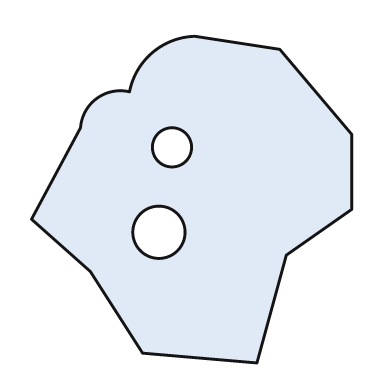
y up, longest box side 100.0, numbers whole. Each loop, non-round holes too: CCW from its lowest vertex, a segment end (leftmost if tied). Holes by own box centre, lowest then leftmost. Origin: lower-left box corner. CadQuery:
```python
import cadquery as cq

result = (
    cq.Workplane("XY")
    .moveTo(69.0, 0.0)
    .lineTo(78.0, 33.0)
    .lineTo(98.0, 47.0)
    .lineTo(98.0, 70.0)
    .lineTo(76.0, 96.0)
    .lineTo(50.0, 100.0)
    .threePointArc((37.0, 95.0), (30.0, 83.0))
    .threePointArc((20.0, 81.0), (15.0, 72.0))
    .lineTo(0.0, 44.0)
    .lineTo(18.0, 28.0)
    .lineTo(34.0, 3.0)
    .close()
    .moveTo(39.0, 40.0)
    .circle(8.0)
    .moveTo(43.0, 66.0)
    .circle(6.0)
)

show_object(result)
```